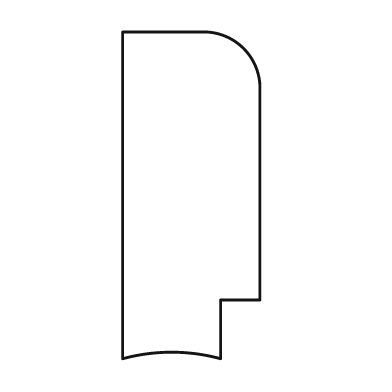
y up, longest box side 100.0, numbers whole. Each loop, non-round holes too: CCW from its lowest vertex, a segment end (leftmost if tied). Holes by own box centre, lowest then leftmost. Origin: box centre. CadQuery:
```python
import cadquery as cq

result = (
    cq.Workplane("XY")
    .moveTo(-21.0, -50.0)
    .threePointArc((-6.0, -48.0), (9.0, -50.0))
    .lineTo(9.0, -32.0)
    .lineTo(21.0, -32.0)
    .lineTo(21.0, 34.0)
    .threePointArc((16.0, 45.0), (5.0, 50.0))
    .lineTo(-21.0, 50.0)
    .close()
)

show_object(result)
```